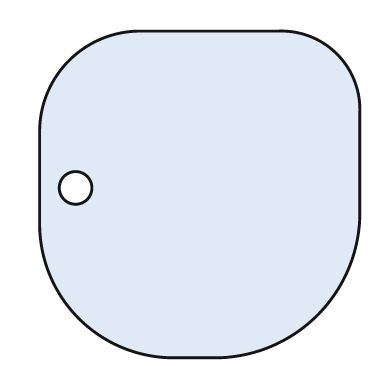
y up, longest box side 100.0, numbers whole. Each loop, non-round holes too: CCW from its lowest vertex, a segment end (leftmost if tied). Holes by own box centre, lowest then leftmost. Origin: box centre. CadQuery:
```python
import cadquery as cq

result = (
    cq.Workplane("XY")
    .moveTo(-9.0, -50.0)
    .lineTo(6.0, -50.0)
    .threePointArc((36.0, -37.0), (49.0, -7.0))
    .lineTo(49.0, 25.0)
    .threePointArc((42.0, 43.0), (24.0, 50.0))
    .lineTo(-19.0, 50.0)
    .threePointArc((-40.0, 41.0), (-49.0, 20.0))
    .lineTo(-49.0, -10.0)
    .threePointArc((-37.0, -38.0), (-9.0, -50.0))
    .close()
    .moveTo(-38.0, 2.0)
    .circle(5.0)
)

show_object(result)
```